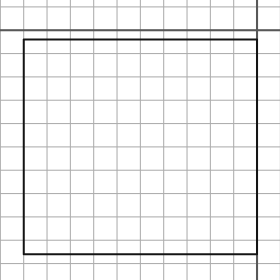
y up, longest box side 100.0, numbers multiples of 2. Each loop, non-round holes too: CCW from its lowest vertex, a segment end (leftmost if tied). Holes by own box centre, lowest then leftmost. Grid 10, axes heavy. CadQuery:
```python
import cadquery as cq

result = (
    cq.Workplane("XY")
    .moveTo(-100.0, -96.0)
    .lineTo(0.0, -96.0)
    .lineTo(0.0, -4.0)
    .lineTo(-100.0, -4.0)
    .close()
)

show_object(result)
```